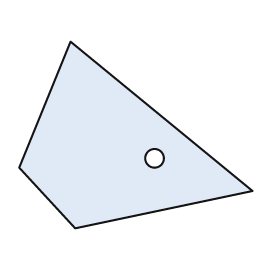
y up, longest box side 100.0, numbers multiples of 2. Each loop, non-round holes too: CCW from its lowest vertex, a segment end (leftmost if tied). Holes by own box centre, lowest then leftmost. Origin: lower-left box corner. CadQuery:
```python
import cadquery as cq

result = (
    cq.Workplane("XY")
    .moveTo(24.0, 0.0)
    .lineTo(100.0, 16.0)
    .lineTo(22.0, 80.0)
    .lineTo(0.0, 26.0)
    .close()
    .moveTo(58.0, 30.0)
    .circle(4.0)
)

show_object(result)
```